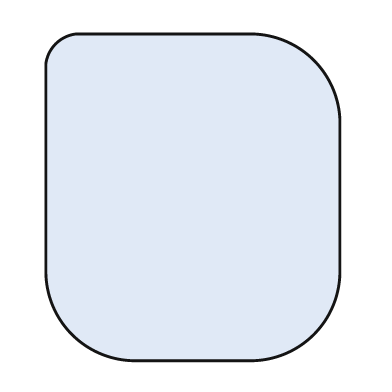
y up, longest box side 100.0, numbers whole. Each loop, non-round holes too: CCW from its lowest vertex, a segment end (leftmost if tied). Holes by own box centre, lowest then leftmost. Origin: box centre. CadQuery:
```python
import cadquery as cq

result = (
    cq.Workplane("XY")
    .moveTo(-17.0, -50.0)
    .lineTo(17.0, -50.0)
    .threePointArc((37.0, -42.0), (45.0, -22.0))
    .lineTo(45.0, 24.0)
    .threePointArc((37.0, 42.0), (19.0, 50.0))
    .lineTo(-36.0, 50.0)
    .threePointArc((-42.0, 47.0), (-45.0, 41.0))
    .lineTo(-45.0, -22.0)
    .threePointArc((-37.0, -42.0), (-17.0, -50.0))
    .close()
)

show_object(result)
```